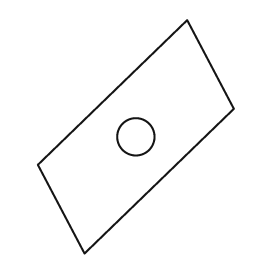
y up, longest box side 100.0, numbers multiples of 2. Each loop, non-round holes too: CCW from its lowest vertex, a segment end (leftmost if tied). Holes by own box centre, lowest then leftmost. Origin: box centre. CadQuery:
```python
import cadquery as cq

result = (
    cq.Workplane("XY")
    .moveTo(-22.0, -50.0)
    .lineTo(42.0, 12.0)
    .lineTo(22.0, 50.0)
    .lineTo(-42.0, -12.0)
    .close()
    .moveTo(0.0, 0.0)
    .circle(8.0)
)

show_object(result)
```